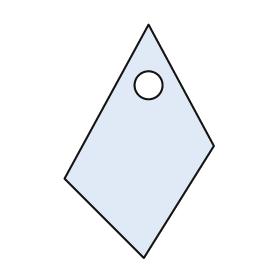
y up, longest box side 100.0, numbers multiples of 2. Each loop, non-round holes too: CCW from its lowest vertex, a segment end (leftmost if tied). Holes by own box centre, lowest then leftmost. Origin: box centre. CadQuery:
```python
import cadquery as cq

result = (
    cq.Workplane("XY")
    .moveTo(2.0, -50.0)
    .lineTo(32.0, -2.0)
    .lineTo(4.0, 50.0)
    .lineTo(-32.0, -16.0)
    .close()
    .moveTo(4.0, 24.0)
    .circle(6.0)
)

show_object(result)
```